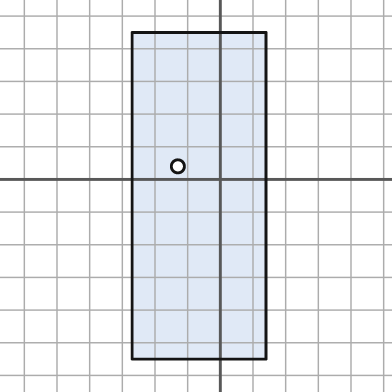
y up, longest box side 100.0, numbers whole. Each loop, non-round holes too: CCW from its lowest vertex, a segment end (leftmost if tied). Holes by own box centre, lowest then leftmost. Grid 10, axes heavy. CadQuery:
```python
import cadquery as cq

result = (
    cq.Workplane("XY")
    .moveTo(-27.0, -55.0)
    .lineTo(14.0, -55.0)
    .lineTo(14.0, 45.0)
    .lineTo(-27.0, 45.0)
    .close()
    .moveTo(-13.0, 4.0)
    .circle(2.0)
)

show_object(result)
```